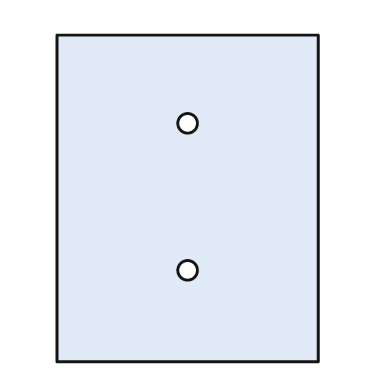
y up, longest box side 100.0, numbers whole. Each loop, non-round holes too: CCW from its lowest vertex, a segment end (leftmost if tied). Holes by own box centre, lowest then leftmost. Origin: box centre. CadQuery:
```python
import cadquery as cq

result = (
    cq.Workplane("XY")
    .moveTo(-40.0, -50.0)
    .lineTo(40.0, -50.0)
    .lineTo(40.0, 50.0)
    .lineTo(-40.0, 50.0)
    .close()
    .moveTo(0.0, -22.0)
    .circle(3.0)
    .moveTo(0.0, 23.0)
    .circle(3.0)
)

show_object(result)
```